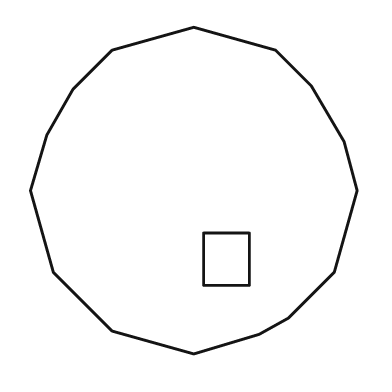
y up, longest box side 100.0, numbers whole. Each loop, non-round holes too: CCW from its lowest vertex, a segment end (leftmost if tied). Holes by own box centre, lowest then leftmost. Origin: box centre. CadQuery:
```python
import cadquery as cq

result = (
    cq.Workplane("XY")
    .moveTo(0.0, -50.0)
    .lineTo(20.0, -44.0)
    .lineTo(29.0, -39.0)
    .lineTo(43.0, -25.0)
    .lineTo(50.0, 0.0)
    .lineTo(46.0, 15.0)
    .lineTo(36.0, 32.0)
    .lineTo(25.0, 43.0)
    .lineTo(0.0, 50.0)
    .lineTo(-25.0, 43.0)
    .lineTo(-37.0, 31.0)
    .lineTo(-45.0, 17.0)
    .lineTo(-50.0, 0.0)
    .lineTo(-43.0, -25.0)
    .lineTo(-25.0, -43.0)
    .close()
    .moveTo(3.0, -29.0)
    .lineTo(17.0, -29.0)
    .lineTo(17.0, -13.0)
    .lineTo(3.0, -13.0)
    .close()
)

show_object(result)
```